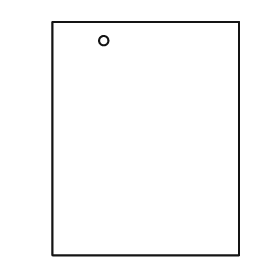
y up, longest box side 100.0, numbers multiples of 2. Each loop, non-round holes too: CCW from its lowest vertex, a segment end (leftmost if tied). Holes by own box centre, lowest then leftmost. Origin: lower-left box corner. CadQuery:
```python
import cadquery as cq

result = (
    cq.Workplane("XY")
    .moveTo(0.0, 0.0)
    .lineTo(80.0, 0.0)
    .lineTo(80.0, 100.0)
    .lineTo(0.0, 100.0)
    .close()
    .moveTo(22.0, 92.0)
    .circle(2.0)
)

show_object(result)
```